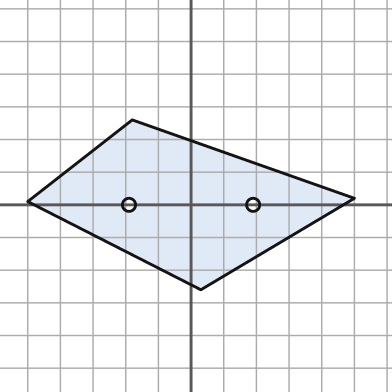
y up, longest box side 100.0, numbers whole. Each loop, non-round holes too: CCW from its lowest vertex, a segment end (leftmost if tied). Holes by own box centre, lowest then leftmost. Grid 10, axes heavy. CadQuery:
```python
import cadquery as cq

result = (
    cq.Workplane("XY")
    .moveTo(3.0, -26.0)
    .lineTo(50.0, 2.0)
    .lineTo(-18.0, 26.0)
    .lineTo(-50.0, 1.0)
    .close()
    .moveTo(-19.0, 0.0)
    .circle(2.0)
    .moveTo(19.0, 0.0)
    .circle(2.0)
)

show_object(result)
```